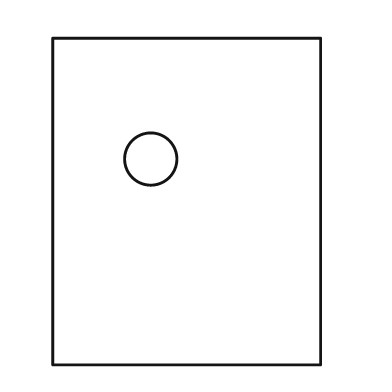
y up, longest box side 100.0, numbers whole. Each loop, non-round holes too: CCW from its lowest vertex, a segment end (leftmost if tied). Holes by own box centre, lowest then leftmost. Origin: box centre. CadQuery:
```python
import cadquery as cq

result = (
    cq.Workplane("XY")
    .moveTo(-41.0, -50.0)
    .lineTo(41.0, -50.0)
    .lineTo(41.0, 50.0)
    .lineTo(-41.0, 50.0)
    .close()
    .moveTo(-11.0, 13.0)
    .circle(8.0)
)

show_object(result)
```